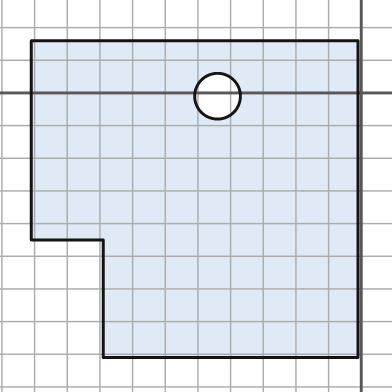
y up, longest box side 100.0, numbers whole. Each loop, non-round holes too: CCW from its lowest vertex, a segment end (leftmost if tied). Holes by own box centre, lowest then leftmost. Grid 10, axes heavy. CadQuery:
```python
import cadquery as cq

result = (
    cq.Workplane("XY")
    .moveTo(-79.0, -81.0)
    .lineTo(-1.0, -81.0)
    .lineTo(-1.0, 16.0)
    .lineTo(-101.0, 16.0)
    .lineTo(-101.0, -45.0)
    .lineTo(-79.0, -45.0)
    .close()
    .moveTo(-44.0, -1.0)
    .circle(7.0)
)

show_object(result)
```